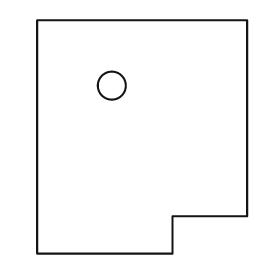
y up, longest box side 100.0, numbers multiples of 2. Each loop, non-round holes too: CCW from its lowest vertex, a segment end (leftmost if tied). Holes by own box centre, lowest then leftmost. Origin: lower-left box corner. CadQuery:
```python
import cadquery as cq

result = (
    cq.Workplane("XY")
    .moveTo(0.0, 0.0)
    .lineTo(58.0, 0.0)
    .lineTo(58.0, 16.0)
    .lineTo(90.0, 16.0)
    .lineTo(90.0, 100.0)
    .lineTo(0.0, 100.0)
    .close()
    .moveTo(32.0, 72.0)
    .circle(6.0)
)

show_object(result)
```